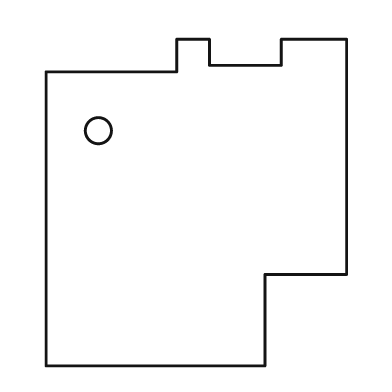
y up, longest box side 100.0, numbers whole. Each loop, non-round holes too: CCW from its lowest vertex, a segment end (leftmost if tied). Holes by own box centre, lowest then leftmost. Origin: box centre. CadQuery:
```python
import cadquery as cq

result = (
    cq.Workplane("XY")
    .moveTo(-46.0, -50.0)
    .lineTo(21.0, -50.0)
    .lineTo(21.0, -22.0)
    .lineTo(46.0, -22.0)
    .lineTo(46.0, 50.0)
    .lineTo(26.0, 50.0)
    .lineTo(26.0, 42.0)
    .lineTo(4.0, 42.0)
    .lineTo(4.0, 50.0)
    .lineTo(-6.0, 50.0)
    .lineTo(-6.0, 40.0)
    .lineTo(-46.0, 40.0)
    .close()
    .moveTo(-30.0, 22.0)
    .circle(4.0)
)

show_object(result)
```